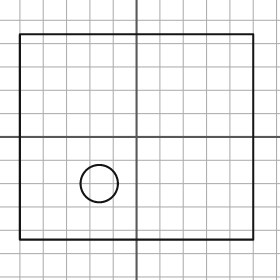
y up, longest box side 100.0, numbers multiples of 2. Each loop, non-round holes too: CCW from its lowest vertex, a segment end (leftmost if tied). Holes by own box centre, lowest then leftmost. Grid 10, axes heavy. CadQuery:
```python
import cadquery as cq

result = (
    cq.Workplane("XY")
    .moveTo(-50.0, -44.0)
    .lineTo(50.0, -44.0)
    .lineTo(50.0, 44.0)
    .lineTo(-50.0, 44.0)
    .close()
    .moveTo(-16.0, -20.0)
    .circle(8.0)
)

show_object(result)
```